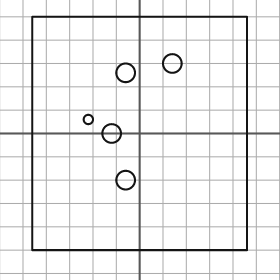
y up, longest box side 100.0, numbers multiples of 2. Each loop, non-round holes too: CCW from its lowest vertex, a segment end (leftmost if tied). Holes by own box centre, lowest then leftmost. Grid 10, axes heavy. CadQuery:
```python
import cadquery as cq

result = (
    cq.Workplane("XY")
    .moveTo(-46.0, -50.0)
    .lineTo(46.0, -50.0)
    .lineTo(46.0, 50.0)
    .lineTo(-46.0, 50.0)
    .close()
    .moveTo(-6.0, -20.0)
    .circle(4.0)
    .moveTo(-12.0, 0.0)
    .circle(4.0)
    .moveTo(-22.0, 6.0)
    .circle(2.0)
    .moveTo(-6.0, 26.0)
    .circle(4.0)
    .moveTo(14.0, 30.0)
    .circle(4.0)
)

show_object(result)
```